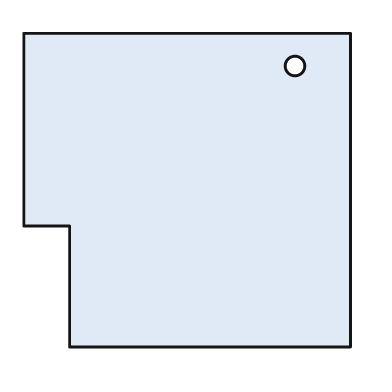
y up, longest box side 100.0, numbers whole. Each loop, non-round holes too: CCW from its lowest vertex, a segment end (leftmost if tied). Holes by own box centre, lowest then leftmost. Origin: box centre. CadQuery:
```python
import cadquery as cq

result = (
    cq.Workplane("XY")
    .moveTo(-36.0, -48.0)
    .lineTo(50.0, -48.0)
    .lineTo(50.0, 48.0)
    .lineTo(-50.0, 48.0)
    .lineTo(-50.0, -11.0)
    .lineTo(-36.0, -11.0)
    .close()
    .moveTo(33.0, 38.0)
    .circle(3.0)
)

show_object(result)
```